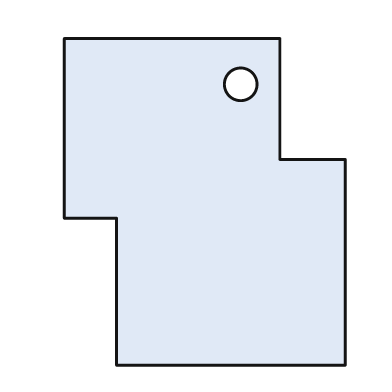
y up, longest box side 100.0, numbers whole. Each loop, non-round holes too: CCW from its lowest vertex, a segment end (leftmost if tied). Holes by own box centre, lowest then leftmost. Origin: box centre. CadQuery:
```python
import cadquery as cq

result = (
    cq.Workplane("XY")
    .moveTo(-27.0, -50.0)
    .lineTo(43.0, -50.0)
    .lineTo(43.0, 13.0)
    .lineTo(23.0, 13.0)
    .lineTo(23.0, 50.0)
    .lineTo(-43.0, 50.0)
    .lineTo(-43.0, -5.0)
    .lineTo(-27.0, -5.0)
    .close()
    .moveTo(11.0, 36.0)
    .circle(5.0)
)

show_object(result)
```